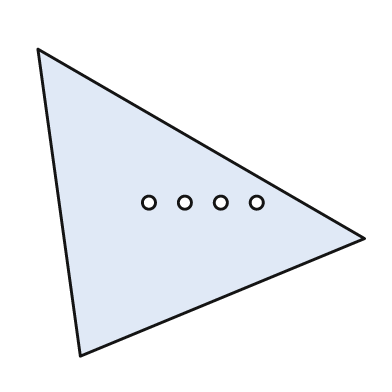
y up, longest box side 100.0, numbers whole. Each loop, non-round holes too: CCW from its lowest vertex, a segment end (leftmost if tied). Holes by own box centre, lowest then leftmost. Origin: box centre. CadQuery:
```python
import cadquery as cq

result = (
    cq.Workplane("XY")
    .moveTo(-37.0, -47.0)
    .lineTo(50.0, -11.0)
    .lineTo(-50.0, 47.0)
    .close()
    .moveTo(-16.0, 0.0)
    .circle(2.0)
    .moveTo(-5.0, 0.0)
    .circle(2.0)
    .moveTo(6.0, 0.0)
    .circle(2.0)
    .moveTo(17.0, 0.0)
    .circle(2.0)
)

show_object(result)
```